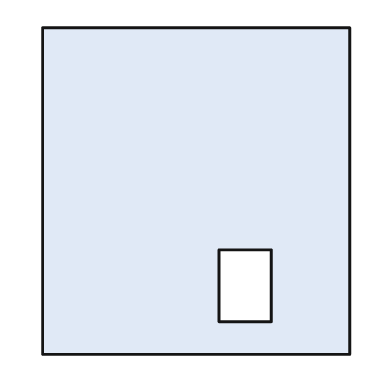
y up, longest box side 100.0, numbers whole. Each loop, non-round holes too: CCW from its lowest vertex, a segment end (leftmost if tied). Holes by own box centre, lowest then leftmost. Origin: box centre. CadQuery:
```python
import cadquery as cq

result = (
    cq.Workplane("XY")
    .moveTo(-47.0, -50.0)
    .lineTo(47.0, -50.0)
    .lineTo(47.0, 50.0)
    .lineTo(-47.0, 50.0)
    .close()
    .moveTo(7.0, -40.0)
    .lineTo(23.0, -40.0)
    .lineTo(23.0, -18.0)
    .lineTo(7.0, -18.0)
    .close()
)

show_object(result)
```